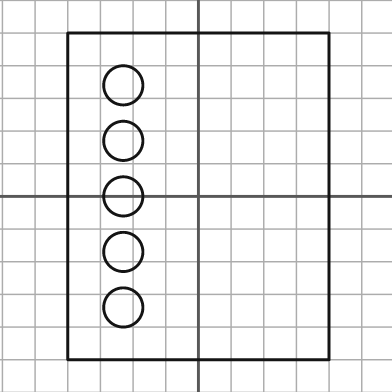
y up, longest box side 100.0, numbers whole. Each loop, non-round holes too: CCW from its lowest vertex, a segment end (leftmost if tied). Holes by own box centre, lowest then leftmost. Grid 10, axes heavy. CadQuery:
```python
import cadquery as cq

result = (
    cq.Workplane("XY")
    .moveTo(-40.0, -50.0)
    .lineTo(40.0, -50.0)
    .lineTo(40.0, 50.0)
    .lineTo(-40.0, 50.0)
    .close()
    .moveTo(-23.0, -34.0)
    .circle(6.0)
    .moveTo(-23.0, -17.0)
    .circle(6.0)
    .moveTo(-23.0, 0.0)
    .circle(6.0)
    .moveTo(-23.0, 17.0)
    .circle(6.0)
    .moveTo(-23.0, 34.0)
    .circle(6.0)
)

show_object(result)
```